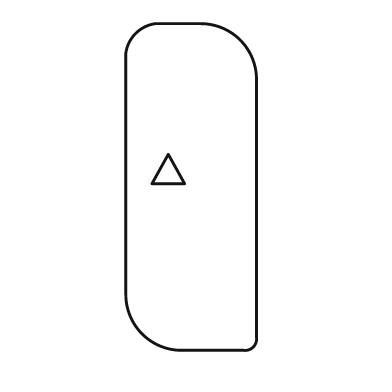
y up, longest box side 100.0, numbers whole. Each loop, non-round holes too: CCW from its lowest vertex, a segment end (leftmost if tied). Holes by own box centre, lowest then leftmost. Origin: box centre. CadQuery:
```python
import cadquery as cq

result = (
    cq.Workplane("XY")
    .moveTo(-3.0, -50.0)
    .lineTo(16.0, -50.0)
    .threePointArc((19.0, -49.0), (20.0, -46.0))
    .lineTo(20.0, 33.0)
    .threePointArc((15.0, 45.0), (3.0, 50.0))
    .lineTo(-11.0, 50.0)
    .threePointArc((-17.0, 47.0), (-20.0, 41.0))
    .lineTo(-20.0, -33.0)
    .threePointArc((-15.0, -45.0), (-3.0, -50.0))
    .close()
    .moveTo(-12.0, 1.0)
    .lineTo(-2.0, 1.0)
    .lineTo(-7.0, 10.0)
    .close()
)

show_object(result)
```